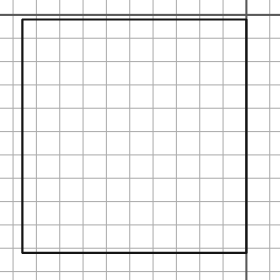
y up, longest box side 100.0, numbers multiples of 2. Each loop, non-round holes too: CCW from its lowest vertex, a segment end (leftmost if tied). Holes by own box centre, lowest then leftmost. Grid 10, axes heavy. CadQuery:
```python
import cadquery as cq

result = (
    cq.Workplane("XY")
    .moveTo(-96.0, -102.0)
    .lineTo(0.0, -102.0)
    .lineTo(0.0, -2.0)
    .lineTo(-96.0, -2.0)
    .close()
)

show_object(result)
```